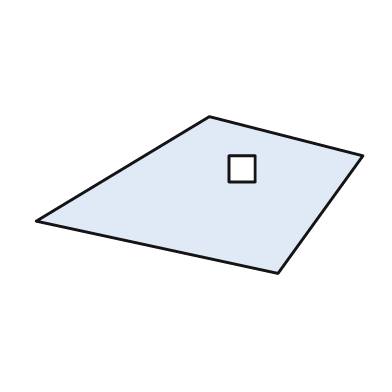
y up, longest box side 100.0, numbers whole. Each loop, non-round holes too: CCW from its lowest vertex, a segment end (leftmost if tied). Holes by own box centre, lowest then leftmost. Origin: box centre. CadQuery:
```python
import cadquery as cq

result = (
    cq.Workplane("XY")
    .moveTo(24.0, -24.0)
    .lineTo(50.0, 12.0)
    .lineTo(3.0, 24.0)
    .lineTo(-50.0, -8.0)
    .close()
    .moveTo(9.0, 4.0)
    .lineTo(17.0, 4.0)
    .lineTo(17.0, 12.0)
    .lineTo(9.0, 12.0)
    .close()
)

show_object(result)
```